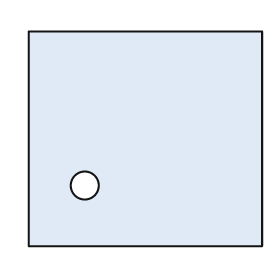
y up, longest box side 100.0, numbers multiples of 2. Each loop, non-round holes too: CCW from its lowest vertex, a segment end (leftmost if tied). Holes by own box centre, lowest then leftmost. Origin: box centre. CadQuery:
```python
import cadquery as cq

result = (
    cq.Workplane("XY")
    .moveTo(-50.0, -46.0)
    .lineTo(50.0, -46.0)
    .lineTo(50.0, 46.0)
    .lineTo(-50.0, 46.0)
    .close()
    .moveTo(-26.0, -20.0)
    .circle(6.0)
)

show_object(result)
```